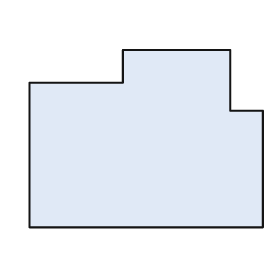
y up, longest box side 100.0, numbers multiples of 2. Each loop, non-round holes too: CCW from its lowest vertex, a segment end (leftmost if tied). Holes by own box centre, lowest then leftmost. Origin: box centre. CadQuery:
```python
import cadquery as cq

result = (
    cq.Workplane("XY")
    .moveTo(-50.0, -38.0)
    .lineTo(50.0, -38.0)
    .lineTo(50.0, 12.0)
    .lineTo(36.0, 12.0)
    .lineTo(36.0, 38.0)
    .lineTo(-10.0, 38.0)
    .lineTo(-10.0, 24.0)
    .lineTo(-50.0, 24.0)
    .close()
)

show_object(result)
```